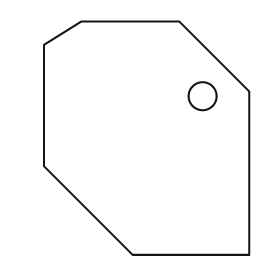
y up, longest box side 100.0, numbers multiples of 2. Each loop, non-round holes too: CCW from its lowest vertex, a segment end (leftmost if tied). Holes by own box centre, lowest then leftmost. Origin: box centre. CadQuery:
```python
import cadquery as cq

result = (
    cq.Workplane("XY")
    .moveTo(-6.0, -50.0)
    .lineTo(44.0, -50.0)
    .lineTo(44.0, 20.0)
    .lineTo(14.0, 50.0)
    .lineTo(-28.0, 50.0)
    .lineTo(-44.0, 40.0)
    .lineTo(-44.0, -12.0)
    .close()
    .moveTo(24.0, 18.0)
    .circle(6.0)
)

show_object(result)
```